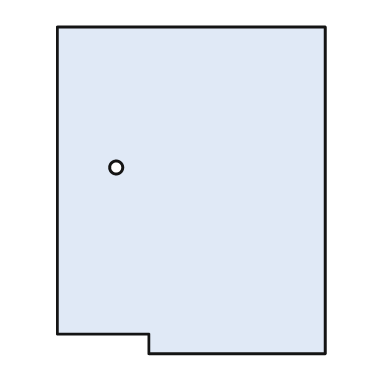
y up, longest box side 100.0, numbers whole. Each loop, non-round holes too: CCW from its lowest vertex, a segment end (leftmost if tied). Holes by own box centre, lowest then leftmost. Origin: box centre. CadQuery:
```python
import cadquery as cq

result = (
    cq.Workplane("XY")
    .moveTo(-13.0, -50.0)
    .lineTo(41.0, -50.0)
    .lineTo(41.0, 50.0)
    .lineTo(-41.0, 50.0)
    .lineTo(-41.0, -44.0)
    .lineTo(-13.0, -44.0)
    .close()
    .moveTo(-23.0, 7.0)
    .circle(2.0)
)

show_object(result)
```